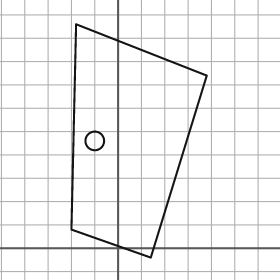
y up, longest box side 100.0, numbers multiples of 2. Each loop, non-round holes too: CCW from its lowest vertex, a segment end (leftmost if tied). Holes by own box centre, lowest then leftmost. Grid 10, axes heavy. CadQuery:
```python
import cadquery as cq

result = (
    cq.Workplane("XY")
    .moveTo(14.0, -4.0)
    .lineTo(38.0, 74.0)
    .lineTo(-18.0, 96.0)
    .lineTo(-20.0, 8.0)
    .close()
    .moveTo(-10.0, 46.0)
    .circle(4.0)
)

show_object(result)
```